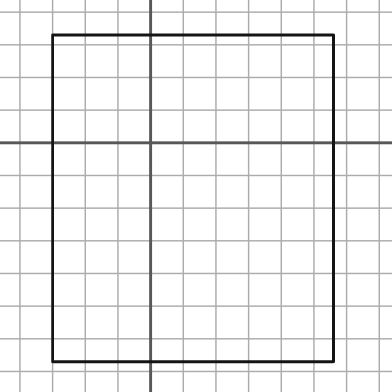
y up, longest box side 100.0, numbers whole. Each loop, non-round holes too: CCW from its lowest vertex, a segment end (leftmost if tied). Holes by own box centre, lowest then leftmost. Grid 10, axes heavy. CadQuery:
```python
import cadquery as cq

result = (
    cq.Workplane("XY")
    .moveTo(-30.0, -67.0)
    .lineTo(56.0, -67.0)
    .lineTo(56.0, 33.0)
    .lineTo(-30.0, 33.0)
    .close()
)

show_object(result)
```